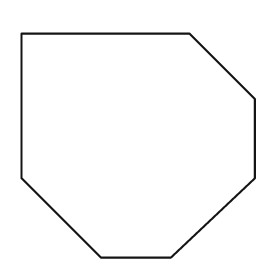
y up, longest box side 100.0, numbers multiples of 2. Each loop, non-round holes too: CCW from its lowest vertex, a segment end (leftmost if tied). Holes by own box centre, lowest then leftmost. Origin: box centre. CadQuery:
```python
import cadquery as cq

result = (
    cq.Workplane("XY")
    .moveTo(-16.0, -48.0)
    .lineTo(14.0, -48.0)
    .lineTo(50.0, -14.0)
    .lineTo(50.0, 20.0)
    .lineTo(22.0, 48.0)
    .lineTo(-50.0, 48.0)
    .lineTo(-50.0, -14.0)
    .close()
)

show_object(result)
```